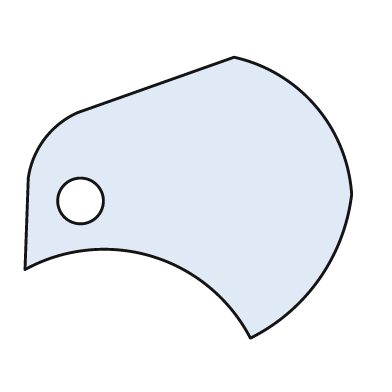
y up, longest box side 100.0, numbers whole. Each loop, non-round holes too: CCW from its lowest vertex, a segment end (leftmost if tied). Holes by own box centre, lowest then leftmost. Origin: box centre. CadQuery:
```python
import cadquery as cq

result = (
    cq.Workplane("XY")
    .moveTo(19.0, -43.0)
    .threePointArc((40.0, -25.0), (50.0, 1.0))
    .threePointArc((39.0, 28.0), (14.0, 43.0))
    .lineTo(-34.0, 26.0)
    .threePointArc((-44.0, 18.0), (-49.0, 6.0))
    .lineTo(-50.0, -22.0)
    .threePointArc((-11.0, -18.0), (19.0, -43.0))
    .close()
    .moveTo(-33.0, -1.0)
    .circle(7.0)
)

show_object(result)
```